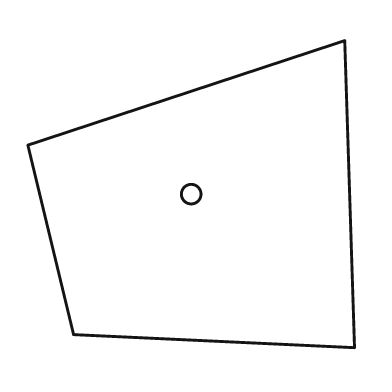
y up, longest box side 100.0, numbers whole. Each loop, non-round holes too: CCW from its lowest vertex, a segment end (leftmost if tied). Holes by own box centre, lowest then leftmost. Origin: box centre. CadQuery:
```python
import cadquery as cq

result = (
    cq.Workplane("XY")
    .moveTo(50.0, -47.0)
    .lineTo(47.0, 47.0)
    .lineTo(-50.0, 15.0)
    .lineTo(-36.0, -43.0)
    .close()
    .moveTo(0.0, 0.0)
    .circle(3.0)
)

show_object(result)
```